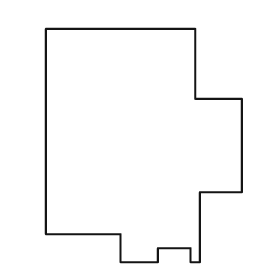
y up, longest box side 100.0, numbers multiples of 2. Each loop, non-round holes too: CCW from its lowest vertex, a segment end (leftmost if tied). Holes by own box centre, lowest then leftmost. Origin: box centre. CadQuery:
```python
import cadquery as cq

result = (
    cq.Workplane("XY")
    .moveTo(-10.0, -50.0)
    .lineTo(6.0, -50.0)
    .lineTo(6.0, -44.0)
    .lineTo(20.0, -44.0)
    .lineTo(20.0, -50.0)
    .lineTo(24.0, -50.0)
    .lineTo(24.0, -20.0)
    .lineTo(42.0, -20.0)
    .lineTo(42.0, 20.0)
    .lineTo(22.0, 20.0)
    .lineTo(22.0, 50.0)
    .lineTo(-42.0, 50.0)
    .lineTo(-42.0, -38.0)
    .lineTo(-10.0, -38.0)
    .close()
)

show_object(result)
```